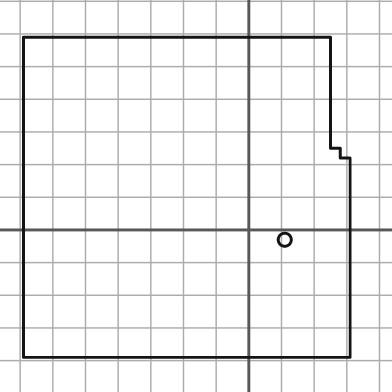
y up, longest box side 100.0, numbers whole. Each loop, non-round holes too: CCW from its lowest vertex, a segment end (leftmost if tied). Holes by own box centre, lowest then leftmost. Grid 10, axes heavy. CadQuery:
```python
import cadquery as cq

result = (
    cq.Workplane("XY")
    .moveTo(-69.0, -39.0)
    .lineTo(31.0, -39.0)
    .lineTo(31.0, 22.0)
    .lineTo(28.0, 22.0)
    .lineTo(28.0, 25.0)
    .lineTo(25.0, 25.0)
    .lineTo(25.0, 59.0)
    .lineTo(-69.0, 59.0)
    .close()
    .moveTo(11.0, -3.0)
    .circle(2.0)
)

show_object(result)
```